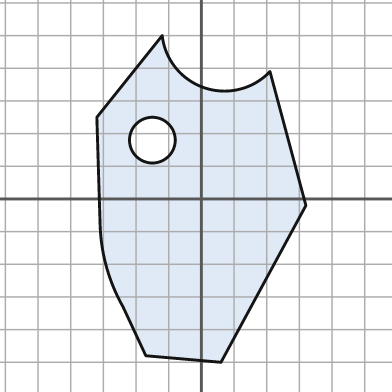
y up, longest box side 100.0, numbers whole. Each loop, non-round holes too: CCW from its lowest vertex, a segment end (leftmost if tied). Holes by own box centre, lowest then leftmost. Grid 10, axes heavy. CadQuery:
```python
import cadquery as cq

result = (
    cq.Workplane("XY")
    .moveTo(6.0, -50.0)
    .lineTo(32.0, -2.0)
    .lineTo(21.0, 39.0)
    .threePointArc((1.0, 34.0), (-12.0, 50.0))
    .lineTo(-32.0, 25.0)
    .lineTo(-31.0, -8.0)
    .threePointArc((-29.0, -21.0), (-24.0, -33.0))
    .lineTo(-17.0, -48.0)
    .close()
    .moveTo(-15.0, 18.0)
    .circle(7.0)
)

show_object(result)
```